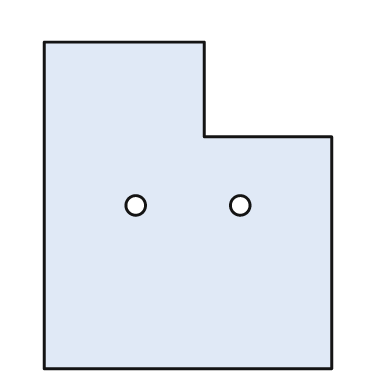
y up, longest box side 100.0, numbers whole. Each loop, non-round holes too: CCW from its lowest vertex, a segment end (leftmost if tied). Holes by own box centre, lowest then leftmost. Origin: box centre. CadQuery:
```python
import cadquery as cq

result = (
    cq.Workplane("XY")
    .moveTo(-44.0, -50.0)
    .lineTo(44.0, -50.0)
    .lineTo(44.0, 21.0)
    .lineTo(5.0, 21.0)
    .lineTo(5.0, 50.0)
    .lineTo(-44.0, 50.0)
    .close()
    .moveTo(-16.0, 0.0)
    .circle(3.0)
    .moveTo(16.0, 0.0)
    .circle(3.0)
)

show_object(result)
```